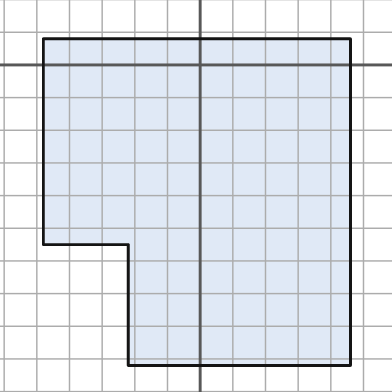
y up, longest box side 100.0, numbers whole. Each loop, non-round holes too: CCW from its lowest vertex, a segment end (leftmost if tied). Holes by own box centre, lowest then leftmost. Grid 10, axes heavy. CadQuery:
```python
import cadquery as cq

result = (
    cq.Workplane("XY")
    .moveTo(-22.0, -92.0)
    .lineTo(46.0, -92.0)
    .lineTo(46.0, 8.0)
    .lineTo(-48.0, 8.0)
    .lineTo(-48.0, -55.0)
    .lineTo(-22.0, -55.0)
    .close()
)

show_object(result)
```